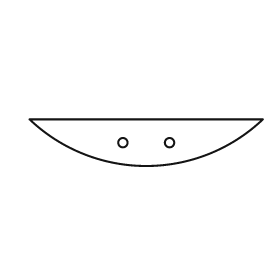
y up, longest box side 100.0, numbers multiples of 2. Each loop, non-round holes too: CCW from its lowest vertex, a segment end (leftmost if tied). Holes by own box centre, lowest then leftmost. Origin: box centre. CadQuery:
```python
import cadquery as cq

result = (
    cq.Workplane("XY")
    .moveTo(-50.0, 10.0)
    .threePointArc((0.0, -10.0), (50.0, 10.0))
    .close()
    .moveTo(-10.0, 0.0)
    .circle(2.0)
    .moveTo(10.0, 0.0)
    .circle(2.0)
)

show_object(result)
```